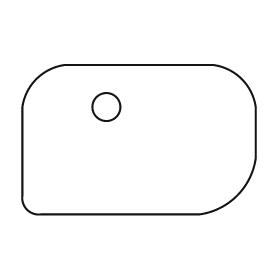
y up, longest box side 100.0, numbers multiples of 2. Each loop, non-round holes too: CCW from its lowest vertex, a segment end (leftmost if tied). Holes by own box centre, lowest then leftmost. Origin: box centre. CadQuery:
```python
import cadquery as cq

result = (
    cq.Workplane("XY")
    .moveTo(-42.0, -32.0)
    .lineTo(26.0, -32.0)
    .threePointArc((42.0, -24.0), (50.0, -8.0))
    .lineTo(50.0, 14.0)
    .threePointArc((44.0, 26.0), (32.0, 32.0))
    .lineTo(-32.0, 32.0)
    .threePointArc((-44.0, 26.0), (-50.0, 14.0))
    .lineTo(-50.0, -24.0)
    .threePointArc((-48.0, -30.0), (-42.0, -32.0))
    .close()
    .moveTo(-14.0, 14.0)
    .circle(6.0)
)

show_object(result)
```